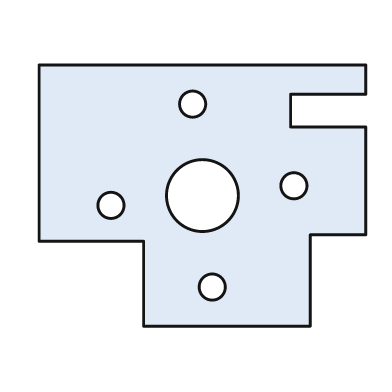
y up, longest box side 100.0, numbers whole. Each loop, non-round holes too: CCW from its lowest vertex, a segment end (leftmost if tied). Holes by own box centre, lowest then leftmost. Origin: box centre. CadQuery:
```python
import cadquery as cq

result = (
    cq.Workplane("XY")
    .moveTo(-18.0, -40.0)
    .lineTo(33.0, -40.0)
    .lineTo(33.0, -12.0)
    .lineTo(50.0, -12.0)
    .lineTo(50.0, 21.0)
    .lineTo(27.0, 21.0)
    .lineTo(27.0, 31.0)
    .lineTo(50.0, 31.0)
    .lineTo(50.0, 40.0)
    .lineTo(-50.0, 40.0)
    .lineTo(-50.0, -14.0)
    .lineTo(-18.0, -14.0)
    .close()
    .moveTo(3.0, -28.0)
    .circle(4.0)
    .moveTo(-28.0, -3.0)
    .circle(4.0)
    .moveTo(0.0, 0.0)
    .circle(11.0)
    .moveTo(28.0, 3.0)
    .circle(4.0)
    .moveTo(-3.0, 28.0)
    .circle(4.0)
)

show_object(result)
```